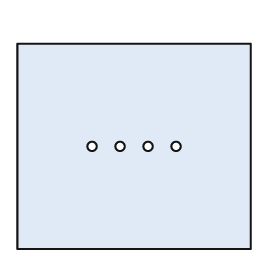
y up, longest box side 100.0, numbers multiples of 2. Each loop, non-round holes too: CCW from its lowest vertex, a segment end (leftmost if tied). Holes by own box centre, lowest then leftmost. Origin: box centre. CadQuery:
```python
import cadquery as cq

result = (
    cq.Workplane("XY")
    .moveTo(-50.0, -44.0)
    .lineTo(50.0, -44.0)
    .lineTo(50.0, 44.0)
    .lineTo(-50.0, 44.0)
    .close()
    .moveTo(-18.0, 0.0)
    .circle(2.0)
    .moveTo(-6.0, 0.0)
    .circle(2.0)
    .moveTo(6.0, 0.0)
    .circle(2.0)
    .moveTo(18.0, 0.0)
    .circle(2.0)
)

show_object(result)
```